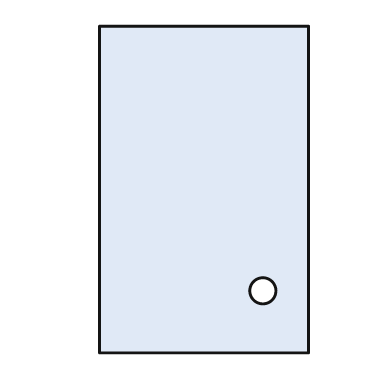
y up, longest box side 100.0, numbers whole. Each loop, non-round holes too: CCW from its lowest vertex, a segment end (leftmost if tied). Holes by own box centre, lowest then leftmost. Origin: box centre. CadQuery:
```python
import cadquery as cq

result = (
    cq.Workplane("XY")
    .moveTo(-32.0, -50.0)
    .lineTo(32.0, -50.0)
    .lineTo(32.0, 50.0)
    .lineTo(-32.0, 50.0)
    .close()
    .moveTo(18.0, -31.0)
    .circle(4.0)
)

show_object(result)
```